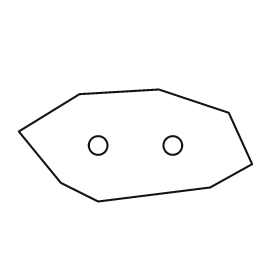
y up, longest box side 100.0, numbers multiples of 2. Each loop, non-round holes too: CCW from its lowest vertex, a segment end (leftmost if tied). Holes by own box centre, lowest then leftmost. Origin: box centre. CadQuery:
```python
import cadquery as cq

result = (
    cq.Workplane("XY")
    .moveTo(-16.0, -24.0)
    .lineTo(32.0, -18.0)
    .lineTo(50.0, -8.0)
    .lineTo(40.0, 14.0)
    .lineTo(10.0, 24.0)
    .lineTo(-24.0, 22.0)
    .lineTo(-50.0, 6.0)
    .lineTo(-32.0, -16.0)
    .close()
    .moveTo(-16.0, 0.0)
    .circle(4.0)
    .moveTo(16.0, 0.0)
    .circle(4.0)
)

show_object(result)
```